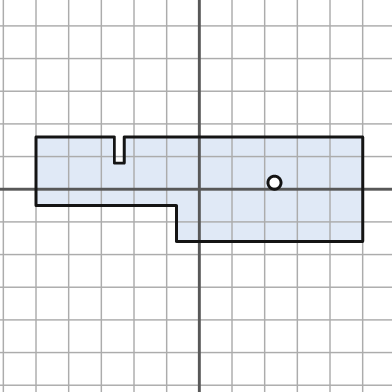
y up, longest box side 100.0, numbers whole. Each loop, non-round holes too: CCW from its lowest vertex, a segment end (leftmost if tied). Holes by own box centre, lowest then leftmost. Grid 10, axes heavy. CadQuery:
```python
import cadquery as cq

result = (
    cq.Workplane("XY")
    .moveTo(-7.0, -16.0)
    .lineTo(50.0, -16.0)
    .lineTo(50.0, 16.0)
    .lineTo(-23.0, 16.0)
    .lineTo(-23.0, 8.0)
    .lineTo(-26.0, 8.0)
    .lineTo(-26.0, 16.0)
    .lineTo(-50.0, 16.0)
    .lineTo(-50.0, -5.0)
    .lineTo(-7.0, -5.0)
    .close()
    .moveTo(23.0, 2.0)
    .circle(2.0)
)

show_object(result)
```